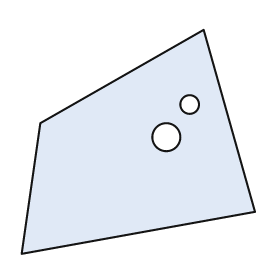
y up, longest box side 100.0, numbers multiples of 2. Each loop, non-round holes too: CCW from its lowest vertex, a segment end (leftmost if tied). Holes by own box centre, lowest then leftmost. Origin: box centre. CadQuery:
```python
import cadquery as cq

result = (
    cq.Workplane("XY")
    .moveTo(-50.0, -48.0)
    .lineTo(50.0, -30.0)
    .lineTo(28.0, 48.0)
    .lineTo(-42.0, 8.0)
    .close()
    .moveTo(12.0, 2.0)
    .circle(6.0)
    .moveTo(22.0, 16.0)
    .circle(4.0)
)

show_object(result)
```